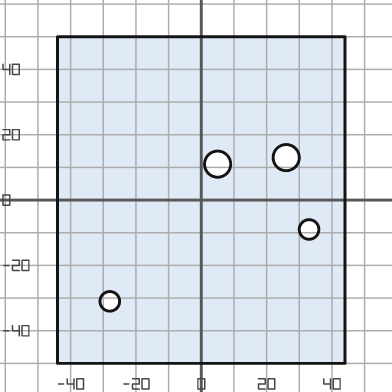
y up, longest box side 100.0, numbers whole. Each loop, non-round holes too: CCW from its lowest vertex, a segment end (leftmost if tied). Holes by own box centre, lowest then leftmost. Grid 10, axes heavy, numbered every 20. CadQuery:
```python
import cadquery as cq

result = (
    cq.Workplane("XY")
    .moveTo(-44.0, -50.0)
    .lineTo(44.0, -50.0)
    .lineTo(44.0, 50.0)
    .lineTo(-44.0, 50.0)
    .close()
    .moveTo(-28.0, -31.0)
    .circle(3.0)
    .moveTo(33.0, -9.0)
    .circle(3.0)
    .moveTo(5.0, 11.0)
    .circle(4.0)
    .moveTo(26.0, 13.0)
    .circle(4.0)
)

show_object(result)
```